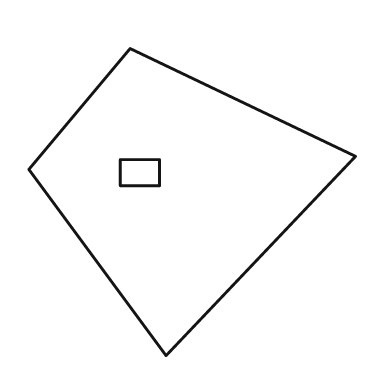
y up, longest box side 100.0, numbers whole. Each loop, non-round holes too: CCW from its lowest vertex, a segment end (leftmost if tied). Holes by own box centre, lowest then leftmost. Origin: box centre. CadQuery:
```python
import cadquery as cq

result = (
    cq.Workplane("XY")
    .moveTo(-8.0, -47.0)
    .lineTo(50.0, 14.0)
    .lineTo(-19.0, 47.0)
    .lineTo(-50.0, 10.0)
    .close()
    .moveTo(-22.0, 5.0)
    .lineTo(-10.0, 5.0)
    .lineTo(-10.0, 13.0)
    .lineTo(-22.0, 13.0)
    .close()
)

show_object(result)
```